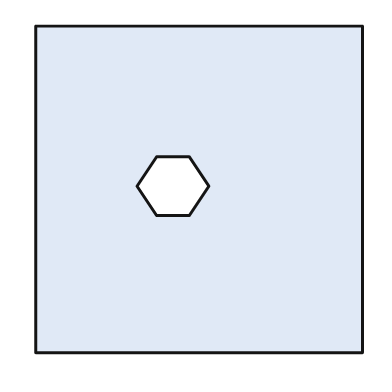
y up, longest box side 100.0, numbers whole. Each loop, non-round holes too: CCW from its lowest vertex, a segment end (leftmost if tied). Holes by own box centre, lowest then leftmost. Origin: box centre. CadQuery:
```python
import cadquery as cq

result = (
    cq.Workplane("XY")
    .moveTo(-50.0, -50.0)
    .lineTo(50.0, -50.0)
    .lineTo(50.0, 50.0)
    .lineTo(-50.0, 50.0)
    .close()
    .moveTo(-13.0, -8.0)
    .lineTo(-3.0, -8.0)
    .lineTo(3.0, 1.0)
    .lineTo(-3.0, 10.0)
    .lineTo(-13.0, 10.0)
    .lineTo(-19.0, 1.0)
    .close()
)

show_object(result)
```